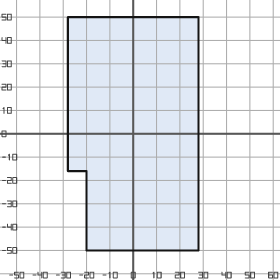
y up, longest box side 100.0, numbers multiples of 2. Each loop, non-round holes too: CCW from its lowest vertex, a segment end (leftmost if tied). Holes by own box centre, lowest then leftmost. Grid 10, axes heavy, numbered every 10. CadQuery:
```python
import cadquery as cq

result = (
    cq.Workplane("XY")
    .moveTo(-20.0, -50.0)
    .lineTo(28.0, -50.0)
    .lineTo(28.0, 50.0)
    .lineTo(-28.0, 50.0)
    .lineTo(-28.0, -16.0)
    .lineTo(-20.0, -16.0)
    .close()
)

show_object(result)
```